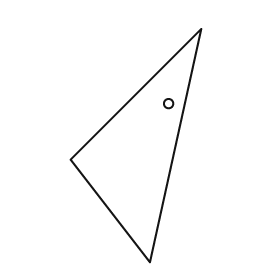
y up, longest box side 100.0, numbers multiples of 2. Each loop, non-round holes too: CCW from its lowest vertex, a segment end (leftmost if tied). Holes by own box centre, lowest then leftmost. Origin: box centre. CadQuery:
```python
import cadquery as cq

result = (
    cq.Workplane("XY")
    .moveTo(6.0, -50.0)
    .lineTo(28.0, 50.0)
    .lineTo(-28.0, -6.0)
    .close()
    .moveTo(14.0, 18.0)
    .circle(2.0)
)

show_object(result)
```